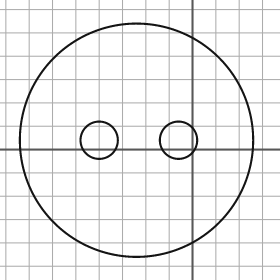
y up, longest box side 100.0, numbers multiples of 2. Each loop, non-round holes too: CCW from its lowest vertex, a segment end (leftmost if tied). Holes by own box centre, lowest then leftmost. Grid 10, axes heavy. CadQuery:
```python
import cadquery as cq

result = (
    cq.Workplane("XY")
    .moveTo(-24.0, 4.0)
    .circle(50.0)
    .moveTo(-40.0, 4.0)
    .circle(8.0)
    .moveTo(-6.0, 4.0)
    .circle(8.0)
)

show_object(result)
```